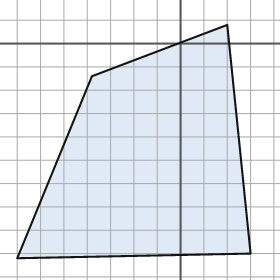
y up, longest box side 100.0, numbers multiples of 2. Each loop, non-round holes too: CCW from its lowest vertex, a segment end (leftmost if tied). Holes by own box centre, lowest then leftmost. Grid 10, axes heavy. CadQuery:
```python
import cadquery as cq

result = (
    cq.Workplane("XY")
    .moveTo(-70.0, -92.0)
    .lineTo(30.0, -90.0)
    .lineTo(20.0, 8.0)
    .lineTo(-38.0, -14.0)
    .close()
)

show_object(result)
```